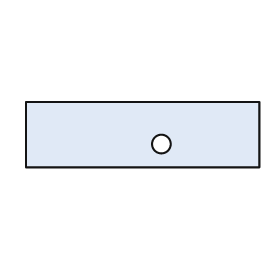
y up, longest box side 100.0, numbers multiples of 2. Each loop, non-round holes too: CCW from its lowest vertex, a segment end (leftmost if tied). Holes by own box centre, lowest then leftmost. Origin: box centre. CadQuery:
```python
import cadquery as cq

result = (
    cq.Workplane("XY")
    .moveTo(-50.0, -14.0)
    .lineTo(50.0, -14.0)
    .lineTo(50.0, 14.0)
    .lineTo(-50.0, 14.0)
    .close()
    .moveTo(8.0, -4.0)
    .circle(4.0)
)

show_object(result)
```